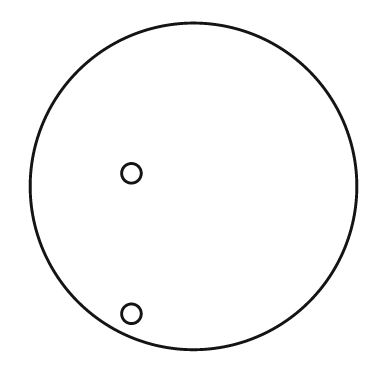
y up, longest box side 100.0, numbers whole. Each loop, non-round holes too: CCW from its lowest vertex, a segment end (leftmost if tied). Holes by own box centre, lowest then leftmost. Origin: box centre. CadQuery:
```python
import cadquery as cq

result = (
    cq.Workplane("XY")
    .moveTo(0.0, 0.0)
    .circle(50.0)
    .moveTo(-19.0, -39.0)
    .circle(3.0)
    .moveTo(-19.0, 4.0)
    .circle(3.0)
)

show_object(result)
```